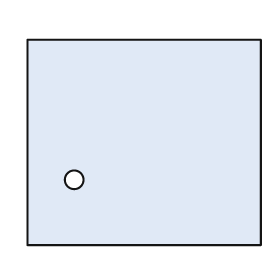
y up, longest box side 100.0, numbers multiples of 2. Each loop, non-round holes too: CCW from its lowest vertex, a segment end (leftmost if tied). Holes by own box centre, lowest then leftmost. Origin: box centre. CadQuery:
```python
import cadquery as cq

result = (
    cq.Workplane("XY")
    .moveTo(-50.0, -44.0)
    .lineTo(50.0, -44.0)
    .lineTo(50.0, 44.0)
    .lineTo(-50.0, 44.0)
    .close()
    .moveTo(-30.0, -16.0)
    .circle(4.0)
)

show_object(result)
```